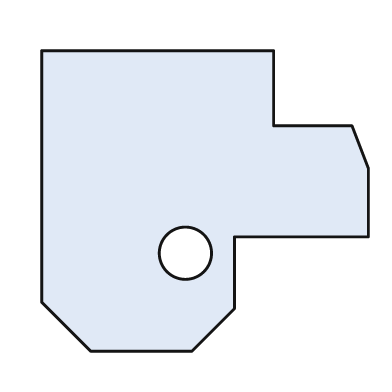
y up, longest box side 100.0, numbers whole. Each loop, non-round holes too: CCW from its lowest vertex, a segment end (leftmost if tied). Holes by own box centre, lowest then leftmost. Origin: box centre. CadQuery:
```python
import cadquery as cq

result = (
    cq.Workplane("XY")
    .moveTo(-35.0, -46.0)
    .lineTo(-4.0, -46.0)
    .lineTo(9.0, -33.0)
    .lineTo(9.0, -11.0)
    .lineTo(50.0, -11.0)
    .lineTo(50.0, 10.0)
    .lineTo(45.0, 23.0)
    .lineTo(21.0, 23.0)
    .lineTo(21.0, 46.0)
    .lineTo(-50.0, 46.0)
    .lineTo(-50.0, -31.0)
    .close()
    .moveTo(-6.0, -16.0)
    .circle(8.0)
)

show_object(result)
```